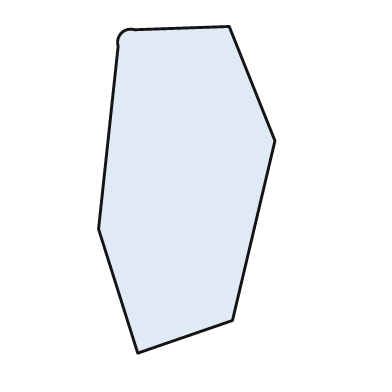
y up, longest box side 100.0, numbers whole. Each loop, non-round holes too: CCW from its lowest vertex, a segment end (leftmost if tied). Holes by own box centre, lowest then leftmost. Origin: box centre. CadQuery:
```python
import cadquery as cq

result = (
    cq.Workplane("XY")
    .moveTo(-15.0, -50.0)
    .lineTo(14.0, -40.0)
    .lineTo(27.0, 15.0)
    .lineTo(13.0, 50.0)
    .lineTo(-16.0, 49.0)
    .threePointArc((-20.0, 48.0), (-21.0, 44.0))
    .lineTo(-27.0, -12.0)
    .close()
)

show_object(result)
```